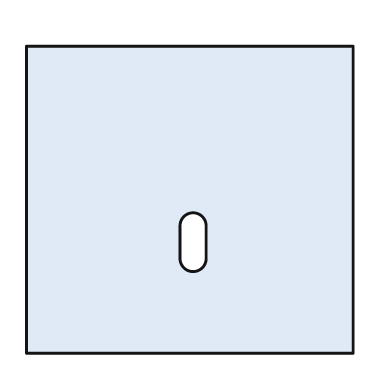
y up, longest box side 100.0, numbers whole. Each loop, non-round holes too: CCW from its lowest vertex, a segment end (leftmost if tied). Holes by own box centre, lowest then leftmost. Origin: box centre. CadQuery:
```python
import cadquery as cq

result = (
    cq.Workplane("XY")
    .moveTo(-50.0, -47.0)
    .lineTo(50.0, -47.0)
    .lineTo(50.0, 47.0)
    .lineTo(-50.0, 47.0)
    .close()
    .moveTo(-3.0, -18.0)
    .threePointArc((1.0, -22.0), (5.0, -18.0))
    .lineTo(5.0, -8.0)
    .threePointArc((1.0, -4.0), (-3.0, -8.0))
    .close()
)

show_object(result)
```